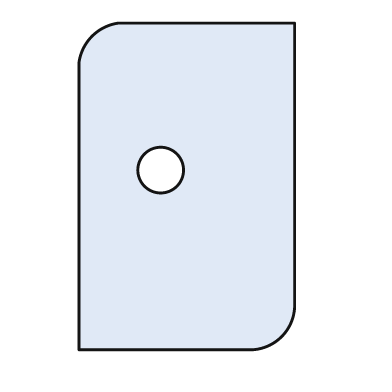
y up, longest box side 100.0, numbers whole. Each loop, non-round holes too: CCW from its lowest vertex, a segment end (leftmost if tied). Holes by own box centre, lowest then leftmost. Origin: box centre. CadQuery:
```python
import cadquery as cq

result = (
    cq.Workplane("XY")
    .moveTo(-33.0, -50.0)
    .lineTo(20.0, -50.0)
    .threePointArc((29.0, -46.0), (33.0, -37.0))
    .lineTo(33.0, 50.0)
    .lineTo(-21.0, 50.0)
    .threePointArc((-29.0, 46.0), (-33.0, 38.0))
    .close()
    .moveTo(-8.0, 5.0)
    .circle(7.0)
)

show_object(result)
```